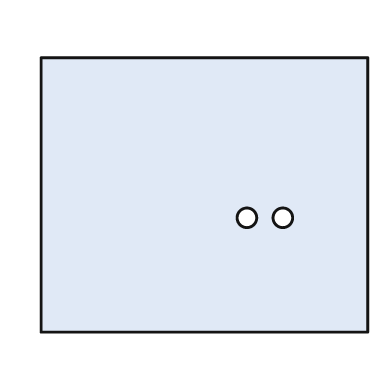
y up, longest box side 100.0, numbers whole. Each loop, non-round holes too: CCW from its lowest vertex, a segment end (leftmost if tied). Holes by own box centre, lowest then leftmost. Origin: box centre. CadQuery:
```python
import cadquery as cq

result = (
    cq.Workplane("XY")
    .moveTo(-50.0, -42.0)
    .lineTo(50.0, -42.0)
    .lineTo(50.0, 42.0)
    .lineTo(-50.0, 42.0)
    .close()
    .moveTo(13.0, -7.0)
    .circle(3.0)
    .moveTo(24.0, -7.0)
    .circle(3.0)
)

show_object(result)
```